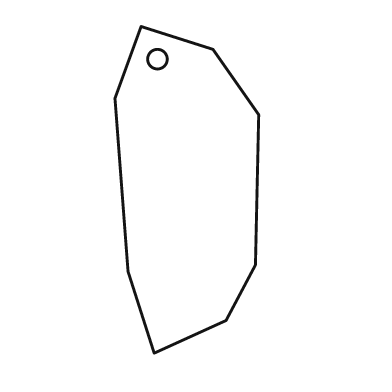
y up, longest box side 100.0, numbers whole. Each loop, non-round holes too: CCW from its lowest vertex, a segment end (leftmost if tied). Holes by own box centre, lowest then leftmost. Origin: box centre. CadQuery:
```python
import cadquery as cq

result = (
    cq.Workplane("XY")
    .moveTo(-10.0, -50.0)
    .lineTo(12.0, -40.0)
    .lineTo(21.0, -23.0)
    .lineTo(22.0, 23.0)
    .lineTo(8.0, 43.0)
    .lineTo(-14.0, 50.0)
    .lineTo(-22.0, 28.0)
    .lineTo(-18.0, -25.0)
    .close()
    .moveTo(-9.0, 40.0)
    .circle(3.0)
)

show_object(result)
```